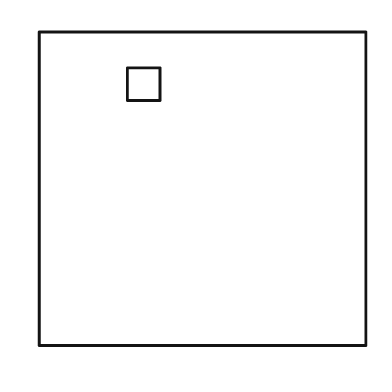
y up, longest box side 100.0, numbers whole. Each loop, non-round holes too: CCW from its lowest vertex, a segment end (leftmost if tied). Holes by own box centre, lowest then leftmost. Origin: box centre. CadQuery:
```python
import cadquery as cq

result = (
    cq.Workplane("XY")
    .moveTo(-50.0, -48.0)
    .lineTo(50.0, -48.0)
    .lineTo(50.0, 48.0)
    .lineTo(-50.0, 48.0)
    .close()
    .moveTo(-23.0, 27.0)
    .lineTo(-13.0, 27.0)
    .lineTo(-13.0, 37.0)
    .lineTo(-23.0, 37.0)
    .close()
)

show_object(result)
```